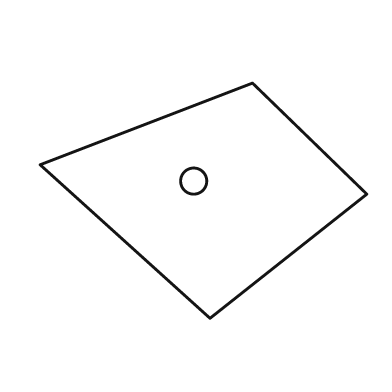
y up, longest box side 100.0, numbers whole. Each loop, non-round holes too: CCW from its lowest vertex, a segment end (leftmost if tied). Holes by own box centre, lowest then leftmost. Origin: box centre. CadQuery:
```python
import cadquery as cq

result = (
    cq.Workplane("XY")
    .moveTo(2.0, -36.0)
    .lineTo(50.0, 2.0)
    .lineTo(15.0, 36.0)
    .lineTo(-50.0, 11.0)
    .close()
    .moveTo(-3.0, 6.0)
    .circle(4.0)
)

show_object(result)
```